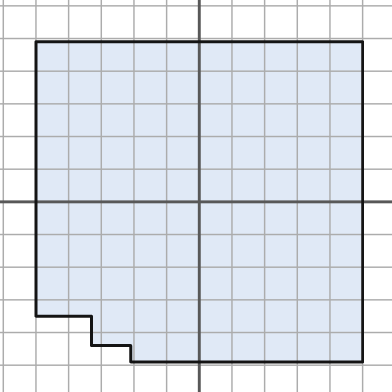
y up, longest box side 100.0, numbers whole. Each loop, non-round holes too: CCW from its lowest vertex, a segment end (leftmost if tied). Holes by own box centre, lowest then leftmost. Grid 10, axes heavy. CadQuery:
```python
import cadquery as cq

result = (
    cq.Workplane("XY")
    .moveTo(-21.0, -49.0)
    .lineTo(50.0, -49.0)
    .lineTo(50.0, 49.0)
    .lineTo(-50.0, 49.0)
    .lineTo(-50.0, -35.0)
    .lineTo(-33.0, -35.0)
    .lineTo(-33.0, -44.0)
    .lineTo(-21.0, -44.0)
    .close()
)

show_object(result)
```